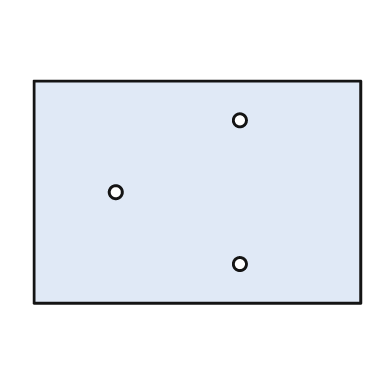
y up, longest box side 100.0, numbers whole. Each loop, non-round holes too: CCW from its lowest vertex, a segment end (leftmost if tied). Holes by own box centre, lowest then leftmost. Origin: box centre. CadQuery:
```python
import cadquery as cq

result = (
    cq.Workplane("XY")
    .moveTo(-50.0, -34.0)
    .lineTo(50.0, -34.0)
    .lineTo(50.0, 34.0)
    .lineTo(-50.0, 34.0)
    .close()
    .moveTo(13.0, -22.0)
    .circle(2.0)
    .moveTo(-25.0, 0.0)
    .circle(2.0)
    .moveTo(13.0, 22.0)
    .circle(2.0)
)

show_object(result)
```